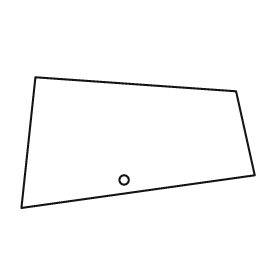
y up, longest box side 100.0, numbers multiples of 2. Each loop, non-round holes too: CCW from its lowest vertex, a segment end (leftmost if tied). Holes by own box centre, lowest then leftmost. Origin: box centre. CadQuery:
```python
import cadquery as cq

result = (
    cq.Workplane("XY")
    .moveTo(-50.0, -28.0)
    .lineTo(50.0, -14.0)
    .lineTo(42.0, 22.0)
    .lineTo(-44.0, 28.0)
    .close()
    .moveTo(-6.0, -16.0)
    .circle(2.0)
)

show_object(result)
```